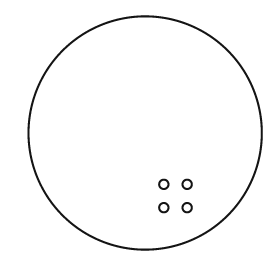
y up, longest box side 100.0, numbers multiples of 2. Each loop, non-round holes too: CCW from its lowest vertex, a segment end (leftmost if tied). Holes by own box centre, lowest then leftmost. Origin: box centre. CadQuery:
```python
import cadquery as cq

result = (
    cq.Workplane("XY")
    .moveTo(0.0, 0.0)
    .circle(50.0)
    .moveTo(8.0, -32.0)
    .circle(2.0)
    .moveTo(18.0, -32.0)
    .circle(2.0)
    .moveTo(8.0, -22.0)
    .circle(2.0)
    .moveTo(18.0, -22.0)
    .circle(2.0)
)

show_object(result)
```